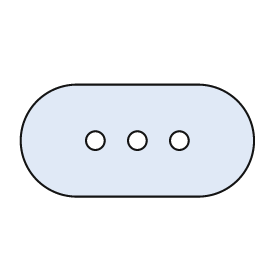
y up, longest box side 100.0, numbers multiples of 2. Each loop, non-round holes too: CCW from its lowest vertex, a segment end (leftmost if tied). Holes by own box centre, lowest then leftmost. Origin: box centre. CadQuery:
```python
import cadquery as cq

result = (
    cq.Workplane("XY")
    .moveTo(-26.0, -24.0)
    .lineTo(26.0, -24.0)
    .threePointArc((50.0, 0.0), (26.0, 24.0))
    .lineTo(-26.0, 24.0)
    .threePointArc((-50.0, 0.0), (-26.0, -24.0))
    .close()
    .moveTo(-18.0, 0.0)
    .circle(4.0)
    .moveTo(0.0, 0.0)
    .circle(4.0)
    .moveTo(18.0, 0.0)
    .circle(4.0)
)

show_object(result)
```